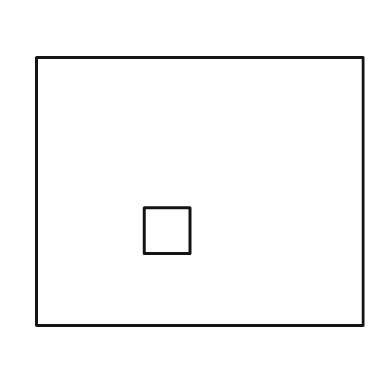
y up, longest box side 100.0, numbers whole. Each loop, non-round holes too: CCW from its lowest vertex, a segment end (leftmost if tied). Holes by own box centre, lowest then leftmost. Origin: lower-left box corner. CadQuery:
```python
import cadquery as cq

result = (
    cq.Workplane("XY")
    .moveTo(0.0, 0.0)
    .lineTo(100.0, 0.0)
    .lineTo(100.0, 82.0)
    .lineTo(0.0, 82.0)
    .close()
    .moveTo(33.0, 22.0)
    .lineTo(47.0, 22.0)
    .lineTo(47.0, 36.0)
    .lineTo(33.0, 36.0)
    .close()
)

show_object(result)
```